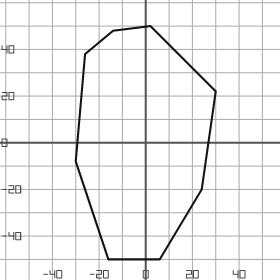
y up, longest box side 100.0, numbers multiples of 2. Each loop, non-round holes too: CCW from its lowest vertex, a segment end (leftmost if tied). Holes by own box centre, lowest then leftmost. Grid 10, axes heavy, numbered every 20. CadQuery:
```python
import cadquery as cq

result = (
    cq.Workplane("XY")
    .moveTo(-16.0, -50.0)
    .lineTo(6.0, -50.0)
    .lineTo(24.0, -20.0)
    .lineTo(30.0, 22.0)
    .lineTo(2.0, 50.0)
    .lineTo(-14.0, 48.0)
    .lineTo(-26.0, 38.0)
    .lineTo(-30.0, -8.0)
    .close()
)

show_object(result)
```